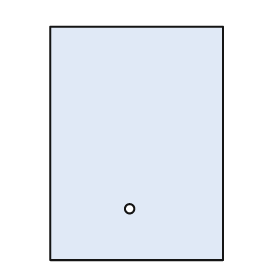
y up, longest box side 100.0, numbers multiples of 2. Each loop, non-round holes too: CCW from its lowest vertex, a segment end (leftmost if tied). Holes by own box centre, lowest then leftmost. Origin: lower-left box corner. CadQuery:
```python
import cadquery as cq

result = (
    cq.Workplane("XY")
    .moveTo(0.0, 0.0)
    .lineTo(74.0, 0.0)
    .lineTo(74.0, 100.0)
    .lineTo(0.0, 100.0)
    .close()
    .moveTo(34.0, 22.0)
    .circle(2.0)
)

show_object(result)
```